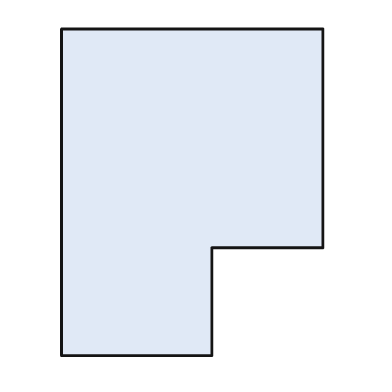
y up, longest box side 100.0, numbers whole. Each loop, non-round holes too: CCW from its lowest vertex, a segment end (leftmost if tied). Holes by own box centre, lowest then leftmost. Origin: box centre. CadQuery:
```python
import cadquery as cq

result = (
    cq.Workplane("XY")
    .moveTo(-40.0, -50.0)
    .lineTo(6.0, -50.0)
    .lineTo(6.0, -17.0)
    .lineTo(40.0, -17.0)
    .lineTo(40.0, 50.0)
    .lineTo(-40.0, 50.0)
    .close()
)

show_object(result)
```